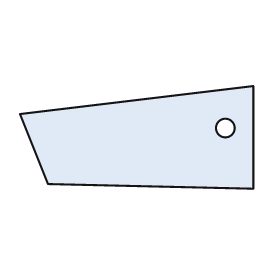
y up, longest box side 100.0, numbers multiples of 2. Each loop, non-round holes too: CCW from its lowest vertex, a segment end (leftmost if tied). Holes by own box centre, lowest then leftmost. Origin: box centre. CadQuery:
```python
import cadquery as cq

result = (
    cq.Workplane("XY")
    .moveTo(50.0, -22.0)
    .lineTo(50.0, 22.0)
    .lineTo(-50.0, 10.0)
    .lineTo(-38.0, -20.0)
    .close()
    .moveTo(38.0, 4.0)
    .circle(4.0)
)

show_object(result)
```